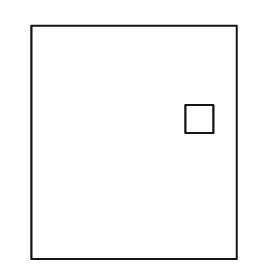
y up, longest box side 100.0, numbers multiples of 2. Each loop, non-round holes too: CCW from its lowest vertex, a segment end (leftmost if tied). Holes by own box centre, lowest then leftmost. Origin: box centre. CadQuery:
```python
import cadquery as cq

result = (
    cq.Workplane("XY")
    .moveTo(-44.0, -50.0)
    .lineTo(44.0, -50.0)
    .lineTo(44.0, 50.0)
    .lineTo(-44.0, 50.0)
    .close()
    .moveTo(22.0, 4.0)
    .lineTo(34.0, 4.0)
    .lineTo(34.0, 16.0)
    .lineTo(22.0, 16.0)
    .close()
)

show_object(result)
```